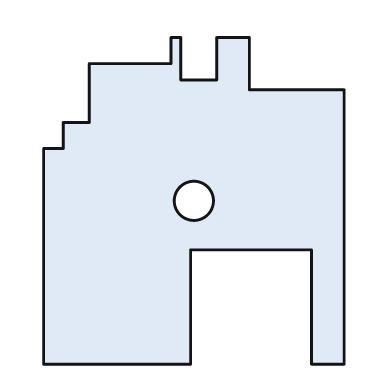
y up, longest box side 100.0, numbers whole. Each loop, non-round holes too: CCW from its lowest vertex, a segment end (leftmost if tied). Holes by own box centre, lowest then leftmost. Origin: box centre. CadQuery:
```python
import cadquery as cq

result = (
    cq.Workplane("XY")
    .moveTo(-46.0, -50.0)
    .lineTo(-1.0, -50.0)
    .lineTo(-1.0, -15.0)
    .lineTo(36.0, -15.0)
    .lineTo(36.0, -50.0)
    .lineTo(46.0, -50.0)
    .lineTo(46.0, 34.0)
    .lineTo(17.0, 34.0)
    .lineTo(17.0, 50.0)
    .lineTo(7.0, 50.0)
    .lineTo(7.0, 37.0)
    .lineTo(-4.0, 37.0)
    .lineTo(-4.0, 50.0)
    .lineTo(-7.0, 50.0)
    .lineTo(-7.0, 42.0)
    .lineTo(-32.0, 42.0)
    .lineTo(-32.0, 24.0)
    .lineTo(-40.0, 24.0)
    .lineTo(-40.0, 16.0)
    .lineTo(-46.0, 16.0)
    .close()
    .moveTo(0.0, 0.0)
    .circle(6.0)
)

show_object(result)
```